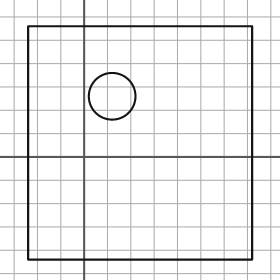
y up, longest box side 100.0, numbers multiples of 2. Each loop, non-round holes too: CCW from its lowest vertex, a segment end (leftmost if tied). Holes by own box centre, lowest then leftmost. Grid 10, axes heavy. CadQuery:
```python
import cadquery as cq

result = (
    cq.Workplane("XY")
    .moveTo(-24.0, -44.0)
    .lineTo(72.0, -44.0)
    .lineTo(72.0, 56.0)
    .lineTo(-24.0, 56.0)
    .close()
    .moveTo(12.0, 26.0)
    .circle(10.0)
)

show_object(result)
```